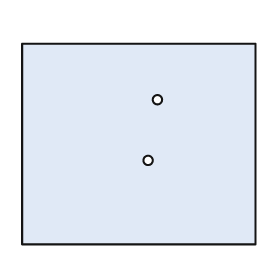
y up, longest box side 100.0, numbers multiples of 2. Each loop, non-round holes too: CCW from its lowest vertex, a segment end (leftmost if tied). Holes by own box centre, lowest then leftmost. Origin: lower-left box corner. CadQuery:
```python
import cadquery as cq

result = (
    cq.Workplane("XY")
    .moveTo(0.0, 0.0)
    .lineTo(100.0, 0.0)
    .lineTo(100.0, 86.0)
    .lineTo(0.0, 86.0)
    .close()
    .moveTo(54.0, 36.0)
    .circle(2.0)
    .moveTo(58.0, 62.0)
    .circle(2.0)
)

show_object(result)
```